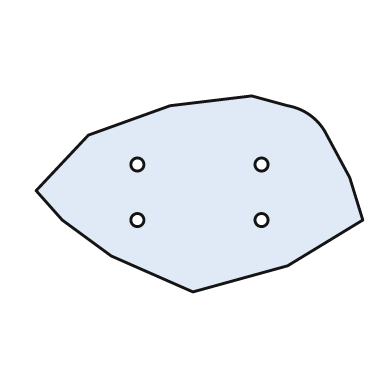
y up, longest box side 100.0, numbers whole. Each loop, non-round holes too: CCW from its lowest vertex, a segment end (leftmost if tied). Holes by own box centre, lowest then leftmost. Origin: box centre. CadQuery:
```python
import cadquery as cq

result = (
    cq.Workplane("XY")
    .moveTo(-2.0, -30.0)
    .lineTo(27.0, -22.0)
    .lineTo(50.0, -8.0)
    .lineTo(46.0, 5.0)
    .lineTo(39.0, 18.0)
    .threePointArc((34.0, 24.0), (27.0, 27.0))
    .lineTo(16.0, 30.0)
    .lineTo(-9.0, 27.0)
    .lineTo(-34.0, 18.0)
    .lineTo(-50.0, 1.0)
    .lineTo(-42.0, -8.0)
    .lineTo(-27.0, -19.0)
    .close()
    .moveTo(-19.0, -8.0)
    .circle(2.0)
    .moveTo(19.0, -8.0)
    .circle(2.0)
    .moveTo(-19.0, 9.0)
    .circle(2.0)
    .moveTo(19.0, 9.0)
    .circle(2.0)
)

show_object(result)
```